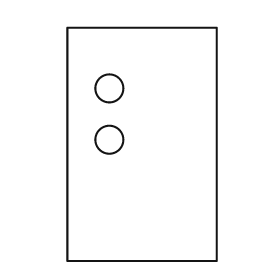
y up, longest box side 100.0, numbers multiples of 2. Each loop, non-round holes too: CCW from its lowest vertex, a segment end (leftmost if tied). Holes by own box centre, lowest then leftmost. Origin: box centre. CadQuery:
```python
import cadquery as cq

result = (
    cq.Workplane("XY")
    .moveTo(-32.0, -50.0)
    .lineTo(32.0, -50.0)
    .lineTo(32.0, 50.0)
    .lineTo(-32.0, 50.0)
    .close()
    .moveTo(-14.0, 2.0)
    .circle(6.0)
    .moveTo(-14.0, 24.0)
    .circle(6.0)
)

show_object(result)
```